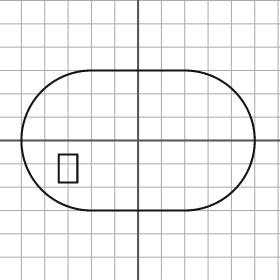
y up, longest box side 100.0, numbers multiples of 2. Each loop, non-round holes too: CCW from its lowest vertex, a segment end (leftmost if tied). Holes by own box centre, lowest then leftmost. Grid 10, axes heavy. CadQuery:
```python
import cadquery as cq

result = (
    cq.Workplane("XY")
    .moveTo(-20.0, -30.0)
    .lineTo(20.0, -30.0)
    .threePointArc((50.0, 0.0), (20.0, 30.0))
    .lineTo(-20.0, 30.0)
    .threePointArc((-50.0, 0.0), (-20.0, -30.0))
    .close()
    .moveTo(-34.0, -18.0)
    .lineTo(-26.0, -18.0)
    .lineTo(-26.0, -6.0)
    .lineTo(-34.0, -6.0)
    .close()
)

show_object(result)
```